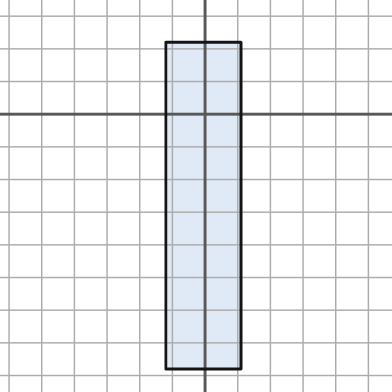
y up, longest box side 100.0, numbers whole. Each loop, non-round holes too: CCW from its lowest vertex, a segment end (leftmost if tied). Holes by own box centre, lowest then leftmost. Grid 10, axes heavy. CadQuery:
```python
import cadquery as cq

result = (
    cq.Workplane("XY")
    .moveTo(-12.0, -78.0)
    .lineTo(11.0, -78.0)
    .lineTo(11.0, 22.0)
    .lineTo(-12.0, 22.0)
    .close()
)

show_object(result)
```